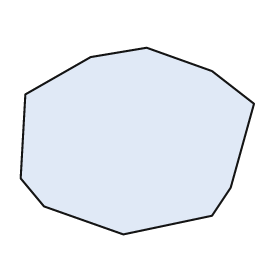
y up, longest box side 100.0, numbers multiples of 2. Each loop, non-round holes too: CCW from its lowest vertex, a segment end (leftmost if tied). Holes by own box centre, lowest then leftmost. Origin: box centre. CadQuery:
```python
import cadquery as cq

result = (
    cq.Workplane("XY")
    .moveTo(-6.0, -40.0)
    .lineTo(32.0, -32.0)
    .lineTo(40.0, -20.0)
    .lineTo(50.0, 16.0)
    .lineTo(32.0, 30.0)
    .lineTo(4.0, 40.0)
    .lineTo(-20.0, 36.0)
    .lineTo(-48.0, 20.0)
    .lineTo(-50.0, -16.0)
    .lineTo(-40.0, -28.0)
    .close()
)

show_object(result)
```